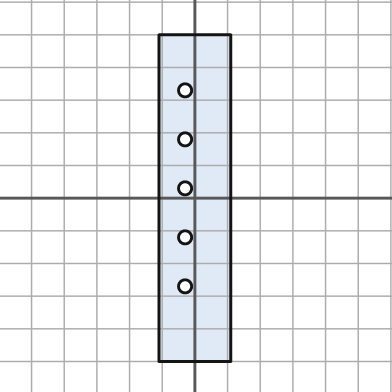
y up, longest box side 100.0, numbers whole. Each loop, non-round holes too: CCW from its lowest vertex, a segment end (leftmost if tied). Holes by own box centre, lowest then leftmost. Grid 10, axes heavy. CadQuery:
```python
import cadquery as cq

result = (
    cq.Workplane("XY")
    .moveTo(-11.0, -50.0)
    .lineTo(11.0, -50.0)
    .lineTo(11.0, 50.0)
    .lineTo(-11.0, 50.0)
    .close()
    .moveTo(-3.0, -27.0)
    .circle(2.0)
    .moveTo(-3.0, -12.0)
    .circle(2.0)
    .moveTo(-3.0, 3.0)
    .circle(2.0)
    .moveTo(-3.0, 18.0)
    .circle(2.0)
    .moveTo(-3.0, 33.0)
    .circle(2.0)
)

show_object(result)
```